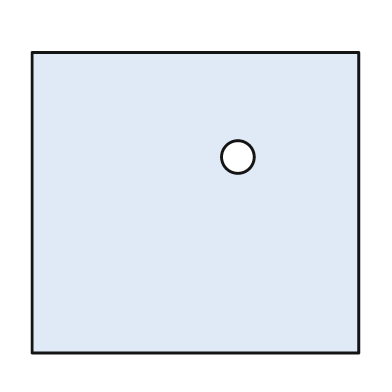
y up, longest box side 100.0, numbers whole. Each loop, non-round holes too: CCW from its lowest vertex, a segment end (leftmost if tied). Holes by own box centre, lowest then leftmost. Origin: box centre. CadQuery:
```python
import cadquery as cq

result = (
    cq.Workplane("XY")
    .moveTo(-50.0, -46.0)
    .lineTo(50.0, -46.0)
    .lineTo(50.0, 46.0)
    .lineTo(-50.0, 46.0)
    .close()
    .moveTo(13.0, 14.0)
    .circle(5.0)
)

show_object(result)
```